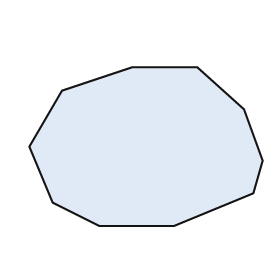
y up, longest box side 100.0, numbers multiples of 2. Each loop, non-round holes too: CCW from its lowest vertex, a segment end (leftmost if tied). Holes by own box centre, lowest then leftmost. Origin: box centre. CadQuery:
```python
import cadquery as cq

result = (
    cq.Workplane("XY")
    .moveTo(-20.0, -34.0)
    .lineTo(12.0, -34.0)
    .lineTo(46.0, -20.0)
    .lineTo(50.0, -6.0)
    .lineTo(42.0, 16.0)
    .lineTo(22.0, 34.0)
    .lineTo(-6.0, 34.0)
    .lineTo(-36.0, 24.0)
    .lineTo(-50.0, 0.0)
    .lineTo(-40.0, -24.0)
    .close()
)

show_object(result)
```